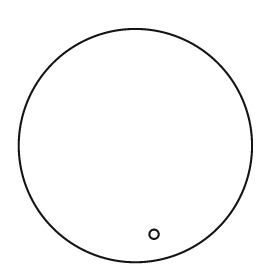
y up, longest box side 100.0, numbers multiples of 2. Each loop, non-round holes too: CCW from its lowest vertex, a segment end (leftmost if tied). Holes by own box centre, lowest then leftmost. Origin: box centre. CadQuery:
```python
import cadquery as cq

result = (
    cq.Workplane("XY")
    .moveTo(0.0, 0.0)
    .circle(50.0)
    .moveTo(8.0, -38.0)
    .circle(2.0)
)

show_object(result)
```